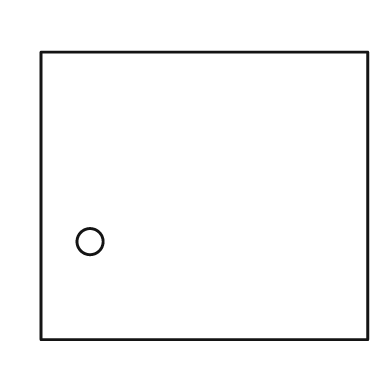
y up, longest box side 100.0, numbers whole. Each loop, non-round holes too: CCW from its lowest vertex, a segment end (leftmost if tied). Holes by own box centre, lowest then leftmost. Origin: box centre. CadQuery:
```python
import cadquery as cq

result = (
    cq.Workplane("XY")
    .moveTo(-50.0, -44.0)
    .lineTo(50.0, -44.0)
    .lineTo(50.0, 44.0)
    .lineTo(-50.0, 44.0)
    .close()
    .moveTo(-35.0, -14.0)
    .circle(4.0)
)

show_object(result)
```